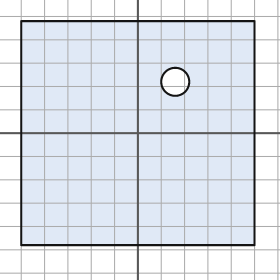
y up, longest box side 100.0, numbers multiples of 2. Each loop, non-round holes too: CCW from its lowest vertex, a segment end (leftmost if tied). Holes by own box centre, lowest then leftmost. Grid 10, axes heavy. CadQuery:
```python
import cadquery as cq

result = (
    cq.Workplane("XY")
    .moveTo(-50.0, -48.0)
    .lineTo(50.0, -48.0)
    .lineTo(50.0, 48.0)
    .lineTo(-50.0, 48.0)
    .close()
    .moveTo(16.0, 22.0)
    .circle(6.0)
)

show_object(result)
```